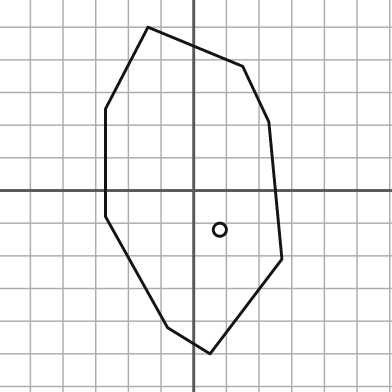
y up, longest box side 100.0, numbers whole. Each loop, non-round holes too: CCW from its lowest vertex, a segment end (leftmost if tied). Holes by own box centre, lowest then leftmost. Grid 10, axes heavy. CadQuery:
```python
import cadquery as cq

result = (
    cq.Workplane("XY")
    .moveTo(5.0, -50.0)
    .lineTo(27.0, -21.0)
    .lineTo(23.0, 21.0)
    .lineTo(15.0, 38.0)
    .lineTo(-14.0, 50.0)
    .lineTo(-27.0, 25.0)
    .lineTo(-27.0, -8.0)
    .lineTo(-8.0, -42.0)
    .close()
    .moveTo(8.0, -12.0)
    .circle(2.0)
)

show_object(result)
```